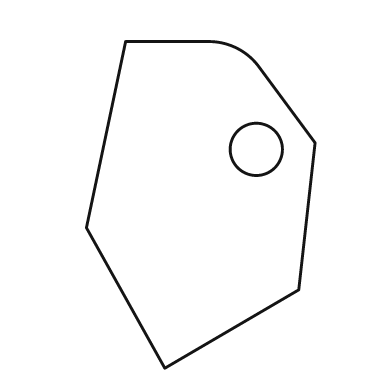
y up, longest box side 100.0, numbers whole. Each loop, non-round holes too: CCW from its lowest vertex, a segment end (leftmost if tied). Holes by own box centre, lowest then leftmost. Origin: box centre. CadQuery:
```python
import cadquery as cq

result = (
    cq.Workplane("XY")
    .moveTo(-11.0, -50.0)
    .lineTo(30.0, -26.0)
    .lineTo(35.0, 19.0)
    .lineTo(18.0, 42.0)
    .threePointArc((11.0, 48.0), (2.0, 50.0))
    .lineTo(-23.0, 50.0)
    .lineTo(-35.0, -7.0)
    .close()
    .moveTo(17.0, 17.0)
    .circle(8.0)
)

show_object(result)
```